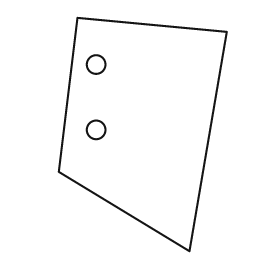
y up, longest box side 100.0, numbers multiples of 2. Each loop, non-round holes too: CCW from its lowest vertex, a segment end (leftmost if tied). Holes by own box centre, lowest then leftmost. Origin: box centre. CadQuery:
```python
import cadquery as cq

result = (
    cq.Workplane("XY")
    .moveTo(20.0, -50.0)
    .lineTo(36.0, 44.0)
    .lineTo(-28.0, 50.0)
    .lineTo(-36.0, -16.0)
    .close()
    .moveTo(-20.0, 2.0)
    .circle(4.0)
    .moveTo(-20.0, 30.0)
    .circle(4.0)
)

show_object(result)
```